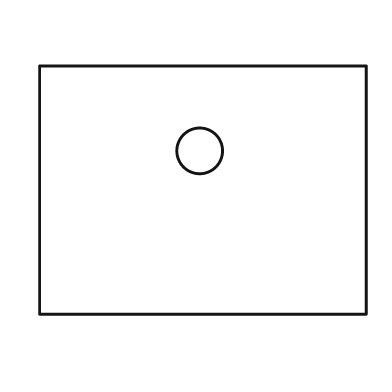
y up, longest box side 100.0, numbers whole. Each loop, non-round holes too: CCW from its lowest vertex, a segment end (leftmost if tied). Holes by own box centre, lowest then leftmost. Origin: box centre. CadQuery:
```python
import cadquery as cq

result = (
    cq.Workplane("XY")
    .moveTo(-50.0, -38.0)
    .lineTo(50.0, -38.0)
    .lineTo(50.0, 38.0)
    .lineTo(-50.0, 38.0)
    .close()
    .moveTo(-1.0, 12.0)
    .circle(7.0)
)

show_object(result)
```